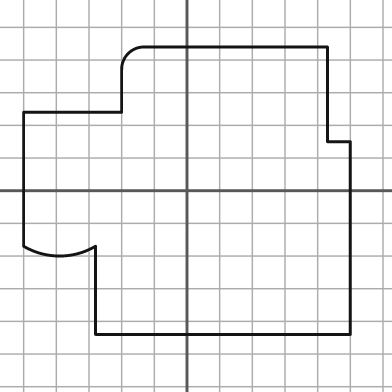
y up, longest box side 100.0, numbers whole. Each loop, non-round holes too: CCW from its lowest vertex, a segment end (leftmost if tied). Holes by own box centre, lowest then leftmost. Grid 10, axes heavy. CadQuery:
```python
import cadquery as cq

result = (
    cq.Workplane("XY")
    .moveTo(-28.0, -44.0)
    .lineTo(50.0, -44.0)
    .lineTo(50.0, 15.0)
    .lineTo(43.0, 15.0)
    .lineTo(43.0, 44.0)
    .lineTo(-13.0, 44.0)
    .threePointArc((-18.0, 42.0), (-20.0, 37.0))
    .lineTo(-20.0, 24.0)
    .lineTo(-50.0, 24.0)
    .lineTo(-50.0, -17.0)
    .threePointArc((-39.0, -20.0), (-28.0, -17.0))
    .close()
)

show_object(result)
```